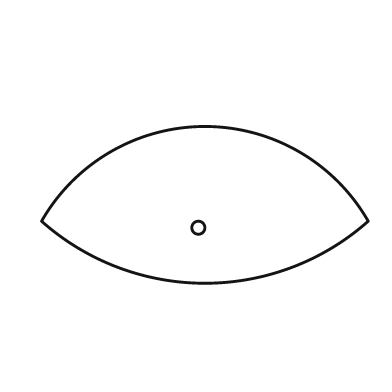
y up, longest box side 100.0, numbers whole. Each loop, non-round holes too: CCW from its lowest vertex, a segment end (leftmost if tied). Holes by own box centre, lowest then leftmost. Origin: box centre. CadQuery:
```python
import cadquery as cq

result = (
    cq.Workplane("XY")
    .moveTo(-50.0, -5.0)
    .threePointArc((0.0, -24.0), (50.0, -5.0))
    .threePointArc((0.0, 24.0), (-50.0, -5.0))
    .close()
    .moveTo(-2.0, -7.0)
    .circle(2.0)
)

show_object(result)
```